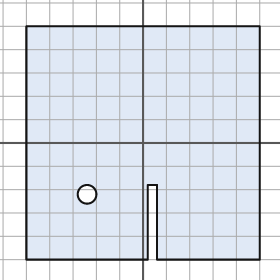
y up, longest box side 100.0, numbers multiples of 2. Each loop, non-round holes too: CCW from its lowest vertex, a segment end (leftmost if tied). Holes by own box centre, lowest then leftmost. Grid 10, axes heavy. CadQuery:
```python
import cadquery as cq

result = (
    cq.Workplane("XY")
    .moveTo(-50.0, -50.0)
    .lineTo(2.0, -50.0)
    .lineTo(2.0, -18.0)
    .lineTo(6.0, -18.0)
    .lineTo(6.0, -50.0)
    .lineTo(50.0, -50.0)
    .lineTo(50.0, 50.0)
    .lineTo(-50.0, 50.0)
    .close()
    .moveTo(-24.0, -22.0)
    .circle(4.0)
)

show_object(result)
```